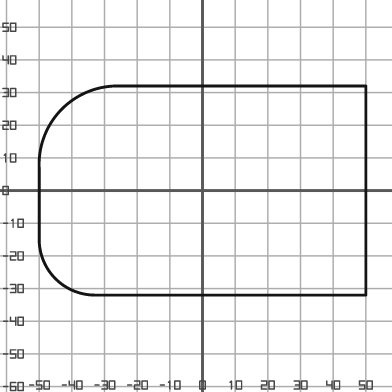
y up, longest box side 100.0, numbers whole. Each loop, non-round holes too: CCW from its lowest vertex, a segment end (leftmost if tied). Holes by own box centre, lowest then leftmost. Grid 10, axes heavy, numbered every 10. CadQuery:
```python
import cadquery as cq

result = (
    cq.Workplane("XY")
    .moveTo(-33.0, -32.0)
    .lineTo(50.0, -32.0)
    .lineTo(50.0, 32.0)
    .lineTo(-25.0, 32.0)
    .threePointArc((-43.0, 25.0), (-50.0, 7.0))
    .lineTo(-50.0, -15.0)
    .threePointArc((-45.0, -27.0), (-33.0, -32.0))
    .close()
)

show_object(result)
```